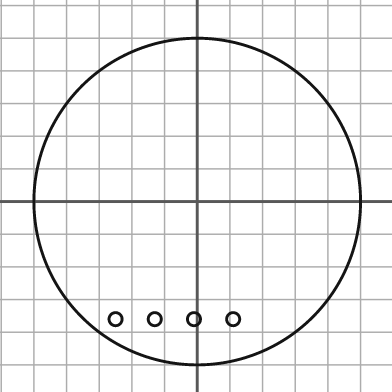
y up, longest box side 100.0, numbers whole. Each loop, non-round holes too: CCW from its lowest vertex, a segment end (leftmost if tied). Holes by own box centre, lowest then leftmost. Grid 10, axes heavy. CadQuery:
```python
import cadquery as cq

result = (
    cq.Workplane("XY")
    .moveTo(0.0, 0.0)
    .circle(50.0)
    .moveTo(-25.0, -36.0)
    .circle(2.0)
    .moveTo(-13.0, -36.0)
    .circle(2.0)
    .moveTo(-1.0, -36.0)
    .circle(2.0)
    .moveTo(11.0, -36.0)
    .circle(2.0)
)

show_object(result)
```